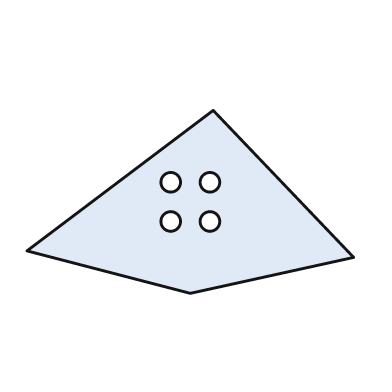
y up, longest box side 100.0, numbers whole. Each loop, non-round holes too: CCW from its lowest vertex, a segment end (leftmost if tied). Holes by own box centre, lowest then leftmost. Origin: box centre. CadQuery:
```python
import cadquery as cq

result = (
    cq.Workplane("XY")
    .moveTo(0.0, -28.0)
    .lineTo(50.0, -17.0)
    .lineTo(7.0, 28.0)
    .lineTo(-50.0, -15.0)
    .close()
    .moveTo(-6.0, -6.0)
    .circle(3.0)
    .moveTo(6.0, -6.0)
    .circle(3.0)
    .moveTo(-6.0, 6.0)
    .circle(3.0)
    .moveTo(6.0, 6.0)
    .circle(3.0)
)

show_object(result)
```